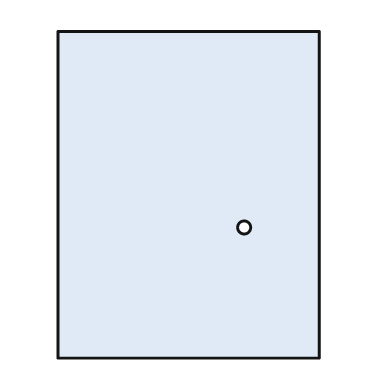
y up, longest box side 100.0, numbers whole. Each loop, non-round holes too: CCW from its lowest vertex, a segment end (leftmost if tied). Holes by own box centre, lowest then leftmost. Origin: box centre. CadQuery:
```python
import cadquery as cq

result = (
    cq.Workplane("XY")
    .moveTo(-40.0, -50.0)
    .lineTo(40.0, -50.0)
    .lineTo(40.0, 50.0)
    .lineTo(-40.0, 50.0)
    .close()
    .moveTo(17.0, -10.0)
    .circle(2.0)
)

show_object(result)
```